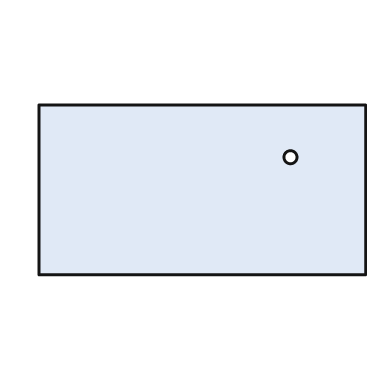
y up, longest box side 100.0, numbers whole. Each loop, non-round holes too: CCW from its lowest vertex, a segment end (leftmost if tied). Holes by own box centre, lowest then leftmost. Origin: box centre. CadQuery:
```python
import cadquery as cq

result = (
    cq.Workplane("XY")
    .moveTo(-50.0, -26.0)
    .lineTo(50.0, -26.0)
    .lineTo(50.0, 26.0)
    .lineTo(-50.0, 26.0)
    .close()
    .moveTo(27.0, 10.0)
    .circle(2.0)
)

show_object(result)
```